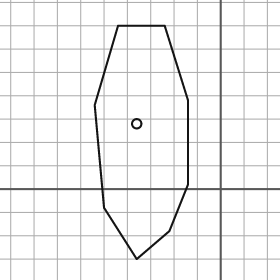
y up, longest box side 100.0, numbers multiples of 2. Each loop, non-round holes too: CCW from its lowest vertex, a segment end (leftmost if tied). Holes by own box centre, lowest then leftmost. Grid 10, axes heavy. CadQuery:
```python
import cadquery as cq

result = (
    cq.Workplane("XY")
    .moveTo(-36.0, -30.0)
    .lineTo(-22.0, -18.0)
    .lineTo(-14.0, 2.0)
    .lineTo(-14.0, 38.0)
    .lineTo(-24.0, 70.0)
    .lineTo(-44.0, 70.0)
    .lineTo(-54.0, 36.0)
    .lineTo(-50.0, -8.0)
    .close()
    .moveTo(-36.0, 28.0)
    .circle(2.0)
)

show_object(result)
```